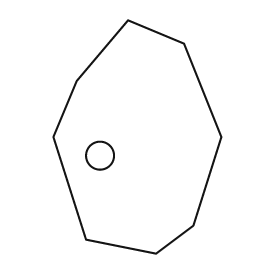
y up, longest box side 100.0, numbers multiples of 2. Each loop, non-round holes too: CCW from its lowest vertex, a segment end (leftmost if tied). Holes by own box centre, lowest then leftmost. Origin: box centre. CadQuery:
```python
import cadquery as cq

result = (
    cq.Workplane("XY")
    .moveTo(8.0, -50.0)
    .lineTo(24.0, -38.0)
    .lineTo(36.0, 0.0)
    .lineTo(20.0, 40.0)
    .lineTo(-4.0, 50.0)
    .lineTo(-26.0, 24.0)
    .lineTo(-36.0, 0.0)
    .lineTo(-22.0, -44.0)
    .close()
    .moveTo(-16.0, -8.0)
    .circle(6.0)
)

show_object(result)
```